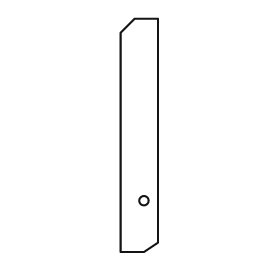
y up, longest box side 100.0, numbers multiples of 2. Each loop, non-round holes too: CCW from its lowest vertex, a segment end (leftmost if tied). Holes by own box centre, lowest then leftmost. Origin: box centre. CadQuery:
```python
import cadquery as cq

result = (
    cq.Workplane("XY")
    .moveTo(-8.0, -50.0)
    .lineTo(2.0, -50.0)
    .lineTo(8.0, -46.0)
    .lineTo(8.0, 50.0)
    .lineTo(-2.0, 50.0)
    .lineTo(-8.0, 44.0)
    .close()
    .moveTo(2.0, -28.0)
    .circle(2.0)
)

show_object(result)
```